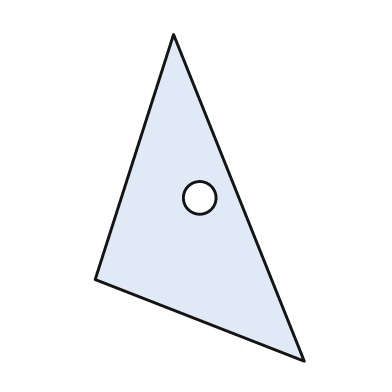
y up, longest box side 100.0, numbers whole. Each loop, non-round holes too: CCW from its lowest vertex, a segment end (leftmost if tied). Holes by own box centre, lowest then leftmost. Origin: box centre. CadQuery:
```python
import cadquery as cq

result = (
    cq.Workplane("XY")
    .moveTo(32.0, -50.0)
    .lineTo(-8.0, 50.0)
    .lineTo(-32.0, -25.0)
    .close()
    .moveTo(0.0, 0.0)
    .circle(5.0)
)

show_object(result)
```